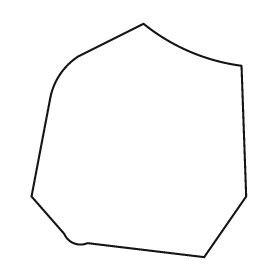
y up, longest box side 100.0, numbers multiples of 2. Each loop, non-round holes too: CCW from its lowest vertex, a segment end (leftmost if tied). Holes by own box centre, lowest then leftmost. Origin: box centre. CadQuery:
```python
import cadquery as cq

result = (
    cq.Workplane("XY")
    .moveTo(28.0, -50.0)
    .lineTo(46.0, -24.0)
    .lineTo(44.0, 32.0)
    .threePointArc((22.0, 38.0), (2.0, 50.0))
    .lineTo(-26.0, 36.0)
    .threePointArc((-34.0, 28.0), (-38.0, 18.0))
    .lineTo(-46.0, -24.0)
    .lineTo(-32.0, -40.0)
    .threePointArc((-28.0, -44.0), (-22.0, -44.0))
    .close()
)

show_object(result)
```